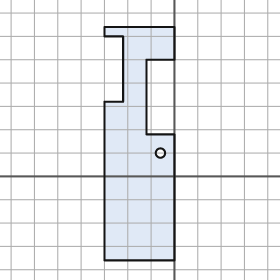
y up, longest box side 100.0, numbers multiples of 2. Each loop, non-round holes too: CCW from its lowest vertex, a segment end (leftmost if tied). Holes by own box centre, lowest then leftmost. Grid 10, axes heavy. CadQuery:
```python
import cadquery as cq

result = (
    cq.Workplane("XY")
    .moveTo(-30.0, -36.0)
    .lineTo(0.0, -36.0)
    .lineTo(0.0, 18.0)
    .lineTo(-12.0, 18.0)
    .lineTo(-12.0, 50.0)
    .lineTo(0.0, 50.0)
    .lineTo(0.0, 64.0)
    .lineTo(-30.0, 64.0)
    .lineTo(-30.0, 60.0)
    .lineTo(-22.0, 60.0)
    .lineTo(-22.0, 32.0)
    .lineTo(-30.0, 32.0)
    .close()
    .moveTo(-6.0, 10.0)
    .circle(2.0)
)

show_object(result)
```